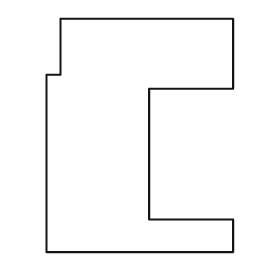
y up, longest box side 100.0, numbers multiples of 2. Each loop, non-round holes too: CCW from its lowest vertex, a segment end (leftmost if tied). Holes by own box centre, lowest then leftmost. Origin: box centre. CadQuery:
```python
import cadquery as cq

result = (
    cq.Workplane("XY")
    .moveTo(-40.0, -50.0)
    .lineTo(40.0, -50.0)
    .lineTo(40.0, -36.0)
    .lineTo(4.0, -36.0)
    .lineTo(4.0, 20.0)
    .lineTo(40.0, 20.0)
    .lineTo(40.0, 50.0)
    .lineTo(-34.0, 50.0)
    .lineTo(-34.0, 26.0)
    .lineTo(-40.0, 26.0)
    .close()
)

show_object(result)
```